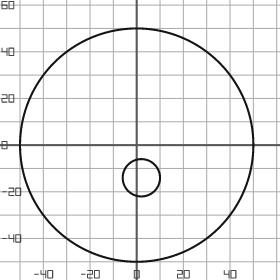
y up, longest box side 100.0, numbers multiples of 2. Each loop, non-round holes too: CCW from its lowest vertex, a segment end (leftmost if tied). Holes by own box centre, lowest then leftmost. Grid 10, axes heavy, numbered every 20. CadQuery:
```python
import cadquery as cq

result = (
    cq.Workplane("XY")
    .moveTo(0.0, 0.0)
    .circle(50.0)
    .moveTo(2.0, -14.0)
    .circle(8.0)
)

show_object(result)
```